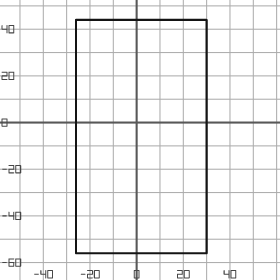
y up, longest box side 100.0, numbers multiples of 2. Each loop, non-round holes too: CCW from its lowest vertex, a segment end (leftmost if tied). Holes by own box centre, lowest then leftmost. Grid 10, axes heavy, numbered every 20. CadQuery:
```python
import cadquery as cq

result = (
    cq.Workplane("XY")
    .moveTo(-26.0, -56.0)
    .lineTo(30.0, -56.0)
    .lineTo(30.0, 44.0)
    .lineTo(-26.0, 44.0)
    .close()
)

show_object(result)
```